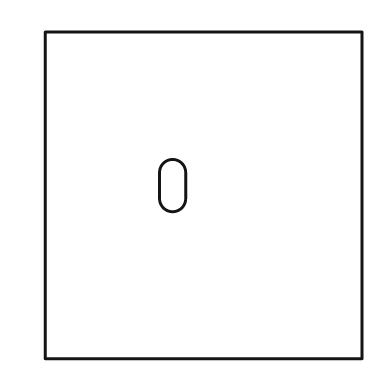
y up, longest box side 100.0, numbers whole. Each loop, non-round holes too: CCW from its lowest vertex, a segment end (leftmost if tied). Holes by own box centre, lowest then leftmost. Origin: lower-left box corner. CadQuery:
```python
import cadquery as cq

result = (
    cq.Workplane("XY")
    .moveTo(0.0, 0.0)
    .lineTo(97.0, 0.0)
    .lineTo(97.0, 100.0)
    .lineTo(0.0, 100.0)
    .close()
    .moveTo(35.0, 49.0)
    .threePointArc((39.0, 45.0), (43.0, 49.0))
    .lineTo(43.0, 57.0)
    .threePointArc((39.0, 61.0), (35.0, 57.0))
    .close()
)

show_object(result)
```